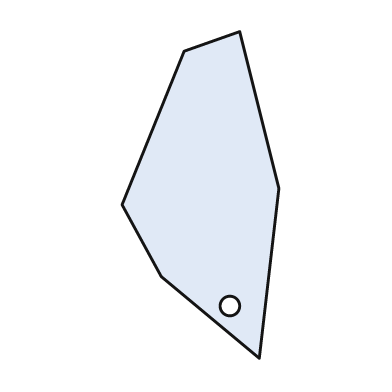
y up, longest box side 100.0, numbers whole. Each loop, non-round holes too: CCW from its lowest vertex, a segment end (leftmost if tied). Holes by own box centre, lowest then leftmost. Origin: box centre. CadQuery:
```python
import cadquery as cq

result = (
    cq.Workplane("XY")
    .moveTo(18.0, -50.0)
    .lineTo(24.0, 2.0)
    .lineTo(12.0, 50.0)
    .lineTo(-5.0, 44.0)
    .lineTo(-24.0, -3.0)
    .lineTo(-12.0, -25.0)
    .close()
    .moveTo(9.0, -34.0)
    .circle(3.0)
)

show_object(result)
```